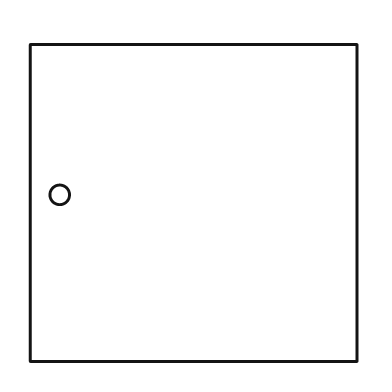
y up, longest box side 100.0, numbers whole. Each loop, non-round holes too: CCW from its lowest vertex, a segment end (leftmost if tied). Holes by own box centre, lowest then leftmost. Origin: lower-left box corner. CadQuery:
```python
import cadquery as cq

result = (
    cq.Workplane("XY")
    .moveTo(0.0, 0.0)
    .lineTo(100.0, 0.0)
    .lineTo(100.0, 97.0)
    .lineTo(0.0, 97.0)
    .close()
    .moveTo(9.0, 51.0)
    .circle(3.0)
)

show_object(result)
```